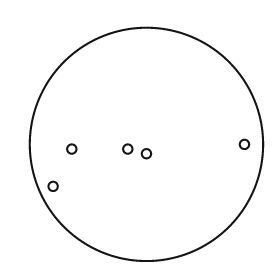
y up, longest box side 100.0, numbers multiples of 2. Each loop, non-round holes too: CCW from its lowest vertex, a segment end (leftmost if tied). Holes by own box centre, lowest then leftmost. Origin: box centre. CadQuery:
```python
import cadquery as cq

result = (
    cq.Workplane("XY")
    .moveTo(0.0, 0.0)
    .circle(50.0)
    .moveTo(-40.0, -18.0)
    .circle(2.0)
    .moveTo(0.0, -4.0)
    .circle(2.0)
    .moveTo(-32.0, -2.0)
    .circle(2.0)
    .moveTo(-8.0, -2.0)
    .circle(2.0)
    .moveTo(42.0, 0.0)
    .circle(2.0)
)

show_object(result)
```